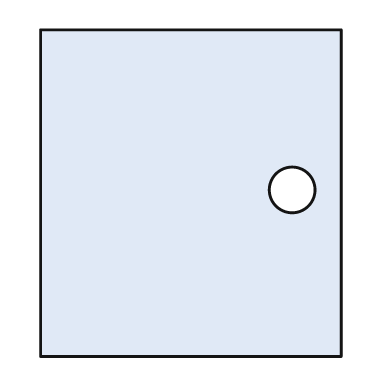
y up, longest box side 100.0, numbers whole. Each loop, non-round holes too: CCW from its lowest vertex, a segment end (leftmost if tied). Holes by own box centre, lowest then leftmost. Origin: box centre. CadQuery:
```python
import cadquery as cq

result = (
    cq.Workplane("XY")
    .moveTo(-46.0, -50.0)
    .lineTo(46.0, -50.0)
    .lineTo(46.0, 50.0)
    .lineTo(-46.0, 50.0)
    .close()
    .moveTo(31.0, 1.0)
    .circle(7.0)
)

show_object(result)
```